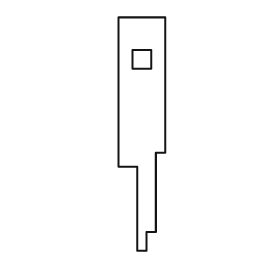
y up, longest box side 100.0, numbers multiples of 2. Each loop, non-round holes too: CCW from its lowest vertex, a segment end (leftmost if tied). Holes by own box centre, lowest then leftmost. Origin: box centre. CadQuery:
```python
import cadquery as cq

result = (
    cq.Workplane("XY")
    .moveTo(-2.0, -50.0)
    .lineTo(2.0, -50.0)
    .lineTo(2.0, -42.0)
    .lineTo(6.0, -42.0)
    .lineTo(6.0, -8.0)
    .lineTo(10.0, -8.0)
    .lineTo(10.0, 50.0)
    .lineTo(-10.0, 50.0)
    .lineTo(-10.0, -14.0)
    .lineTo(-2.0, -14.0)
    .close()
    .moveTo(-4.0, 28.0)
    .lineTo(4.0, 28.0)
    .lineTo(4.0, 36.0)
    .lineTo(-4.0, 36.0)
    .close()
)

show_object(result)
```